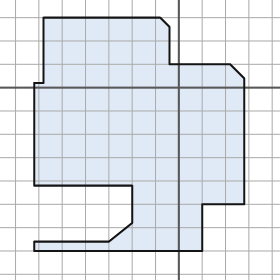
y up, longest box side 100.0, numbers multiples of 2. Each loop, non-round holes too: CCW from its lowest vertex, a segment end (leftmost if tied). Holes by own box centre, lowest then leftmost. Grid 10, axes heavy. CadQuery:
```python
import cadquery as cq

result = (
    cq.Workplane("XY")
    .moveTo(-62.0, -70.0)
    .lineTo(10.0, -70.0)
    .lineTo(10.0, -50.0)
    .lineTo(28.0, -50.0)
    .lineTo(28.0, 4.0)
    .lineTo(22.0, 10.0)
    .lineTo(-4.0, 10.0)
    .lineTo(-4.0, 26.0)
    .lineTo(-8.0, 30.0)
    .lineTo(-58.0, 30.0)
    .lineTo(-58.0, 2.0)
    .lineTo(-62.0, 2.0)
    .lineTo(-62.0, -42.0)
    .lineTo(-20.0, -42.0)
    .lineTo(-20.0, -58.0)
    .lineTo(-30.0, -66.0)
    .lineTo(-62.0, -66.0)
    .close()
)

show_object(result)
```